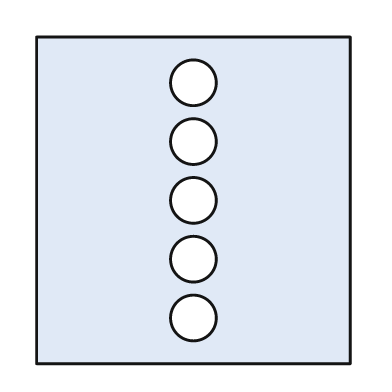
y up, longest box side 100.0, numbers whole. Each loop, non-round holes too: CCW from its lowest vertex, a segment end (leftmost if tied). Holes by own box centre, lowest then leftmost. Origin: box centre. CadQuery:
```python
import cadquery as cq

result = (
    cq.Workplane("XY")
    .moveTo(-48.0, -50.0)
    .lineTo(48.0, -50.0)
    .lineTo(48.0, 50.0)
    .lineTo(-48.0, 50.0)
    .close()
    .moveTo(0.0, -36.0)
    .circle(7.0)
    .moveTo(0.0, -18.0)
    .circle(7.0)
    .moveTo(0.0, 0.0)
    .circle(7.0)
    .moveTo(0.0, 18.0)
    .circle(7.0)
    .moveTo(0.0, 36.0)
    .circle(7.0)
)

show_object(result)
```